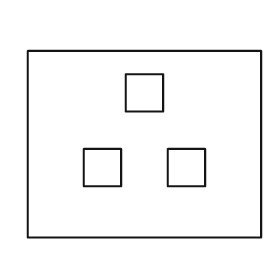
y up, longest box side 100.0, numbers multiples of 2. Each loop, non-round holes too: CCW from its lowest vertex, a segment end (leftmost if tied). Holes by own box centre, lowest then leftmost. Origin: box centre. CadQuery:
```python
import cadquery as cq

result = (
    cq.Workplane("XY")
    .moveTo(-50.0, -40.0)
    .lineTo(50.0, -40.0)
    .lineTo(50.0, 40.0)
    .lineTo(-50.0, 40.0)
    .close()
    .moveTo(-26.0, -18.0)
    .lineTo(-10.0, -18.0)
    .lineTo(-10.0, -2.0)
    .lineTo(-26.0, -2.0)
    .close()
    .moveTo(10.0, -18.0)
    .lineTo(26.0, -18.0)
    .lineTo(26.0, -2.0)
    .lineTo(10.0, -2.0)
    .close()
    .moveTo(-8.0, 14.0)
    .lineTo(8.0, 14.0)
    .lineTo(8.0, 30.0)
    .lineTo(-8.0, 30.0)
    .close()
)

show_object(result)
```